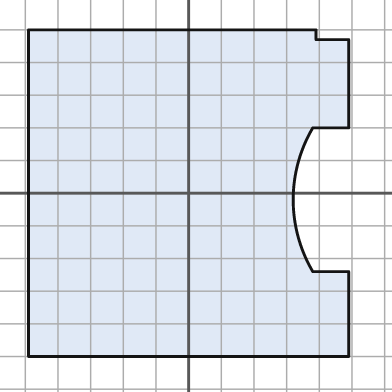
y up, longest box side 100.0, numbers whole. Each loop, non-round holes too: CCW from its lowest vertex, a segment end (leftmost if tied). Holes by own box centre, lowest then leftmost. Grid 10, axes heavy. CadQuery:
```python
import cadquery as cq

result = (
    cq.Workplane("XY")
    .moveTo(-49.0, -50.0)
    .lineTo(49.0, -50.0)
    .lineTo(49.0, -24.0)
    .lineTo(38.0, -24.0)
    .threePointArc((32.0, -2.0), (38.0, 20.0))
    .lineTo(49.0, 20.0)
    .lineTo(49.0, 47.0)
    .lineTo(39.0, 47.0)
    .lineTo(39.0, 50.0)
    .lineTo(-49.0, 50.0)
    .close()
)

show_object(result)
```